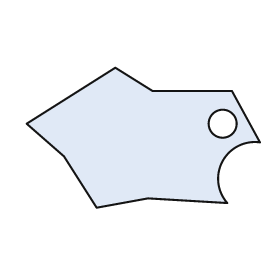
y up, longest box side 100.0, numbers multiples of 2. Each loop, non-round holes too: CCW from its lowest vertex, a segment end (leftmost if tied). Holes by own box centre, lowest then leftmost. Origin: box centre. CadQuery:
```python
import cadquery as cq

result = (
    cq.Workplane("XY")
    .moveTo(-20.0, -30.0)
    .lineTo(2.0, -26.0)
    .lineTo(36.0, -28.0)
    .threePointArc((34.0, -10.0), (50.0, -2.0))
    .lineTo(38.0, 20.0)
    .lineTo(4.0, 20.0)
    .lineTo(-12.0, 30.0)
    .lineTo(-50.0, 6.0)
    .lineTo(-34.0, -8.0)
    .close()
    .moveTo(34.0, 6.0)
    .circle(6.0)
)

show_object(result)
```